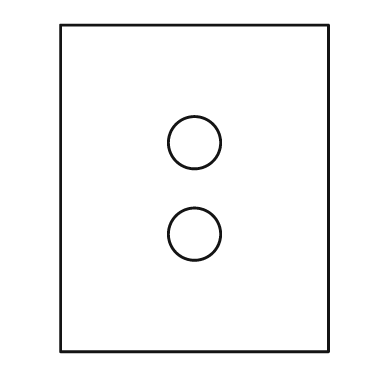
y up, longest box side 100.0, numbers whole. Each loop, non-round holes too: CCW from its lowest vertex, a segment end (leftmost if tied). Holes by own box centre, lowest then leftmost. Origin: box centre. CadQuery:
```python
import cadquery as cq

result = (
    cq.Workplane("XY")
    .moveTo(-41.0, -50.0)
    .lineTo(41.0, -50.0)
    .lineTo(41.0, 50.0)
    .lineTo(-41.0, 50.0)
    .close()
    .moveTo(0.0, -14.0)
    .circle(8.0)
    .moveTo(0.0, 14.0)
    .circle(8.0)
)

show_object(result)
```